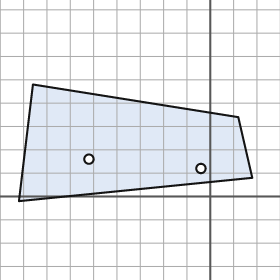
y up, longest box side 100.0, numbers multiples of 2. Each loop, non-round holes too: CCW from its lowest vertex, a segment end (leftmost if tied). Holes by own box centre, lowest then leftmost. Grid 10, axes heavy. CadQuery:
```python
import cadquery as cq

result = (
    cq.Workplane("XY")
    .moveTo(-82.0, -2.0)
    .lineTo(18.0, 8.0)
    .lineTo(12.0, 34.0)
    .lineTo(-76.0, 48.0)
    .close()
    .moveTo(-4.0, 12.0)
    .circle(2.0)
    .moveTo(-52.0, 16.0)
    .circle(2.0)
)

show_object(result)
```